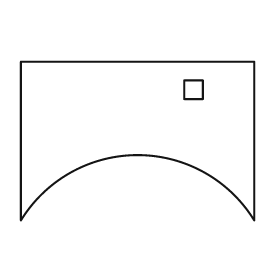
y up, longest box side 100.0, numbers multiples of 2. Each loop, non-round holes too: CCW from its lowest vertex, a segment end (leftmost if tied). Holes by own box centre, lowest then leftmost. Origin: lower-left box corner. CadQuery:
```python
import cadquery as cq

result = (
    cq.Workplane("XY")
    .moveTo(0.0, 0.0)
    .threePointArc((50.0, 28.0), (100.0, 0.0))
    .lineTo(100.0, 68.0)
    .lineTo(0.0, 68.0)
    .close()
    .moveTo(70.0, 52.0)
    .lineTo(78.0, 52.0)
    .lineTo(78.0, 60.0)
    .lineTo(70.0, 60.0)
    .close()
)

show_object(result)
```